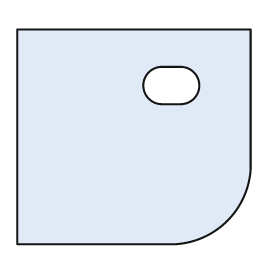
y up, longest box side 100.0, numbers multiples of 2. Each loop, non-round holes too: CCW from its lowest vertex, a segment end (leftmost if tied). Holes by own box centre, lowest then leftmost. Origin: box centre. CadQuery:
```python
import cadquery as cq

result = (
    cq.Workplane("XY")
    .moveTo(-50.0, -46.0)
    .lineTo(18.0, -46.0)
    .threePointArc((40.0, -36.0), (50.0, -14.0))
    .lineTo(50.0, 46.0)
    .lineTo(-50.0, 46.0)
    .close()
    .moveTo(12.0, 14.0)
    .lineTo(20.0, 14.0)
    .threePointArc((28.0, 22.0), (20.0, 30.0))
    .lineTo(12.0, 30.0)
    .threePointArc((4.0, 22.0), (12.0, 14.0))
    .close()
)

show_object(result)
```